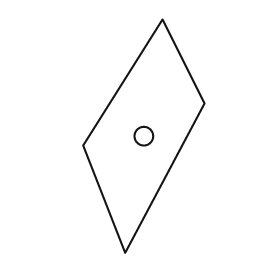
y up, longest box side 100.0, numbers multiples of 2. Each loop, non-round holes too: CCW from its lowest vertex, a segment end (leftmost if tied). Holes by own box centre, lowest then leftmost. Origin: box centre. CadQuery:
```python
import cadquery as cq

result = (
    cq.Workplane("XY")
    .moveTo(-8.0, -50.0)
    .lineTo(26.0, 14.0)
    .lineTo(8.0, 50.0)
    .lineTo(-26.0, -4.0)
    .close()
    .moveTo(0.0, 0.0)
    .circle(4.0)
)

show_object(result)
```